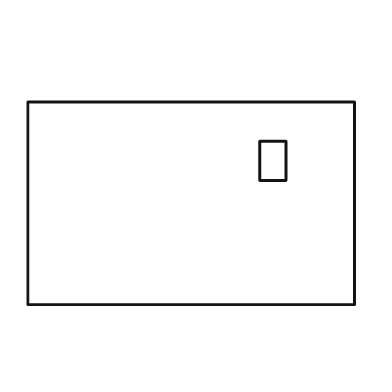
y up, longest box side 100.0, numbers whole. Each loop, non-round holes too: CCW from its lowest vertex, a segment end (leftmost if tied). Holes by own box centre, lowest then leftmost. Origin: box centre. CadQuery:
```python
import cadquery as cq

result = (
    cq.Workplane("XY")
    .moveTo(-50.0, -31.0)
    .lineTo(50.0, -31.0)
    .lineTo(50.0, 31.0)
    .lineTo(-50.0, 31.0)
    .close()
    .moveTo(21.0, 7.0)
    .lineTo(29.0, 7.0)
    .lineTo(29.0, 19.0)
    .lineTo(21.0, 19.0)
    .close()
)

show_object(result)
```